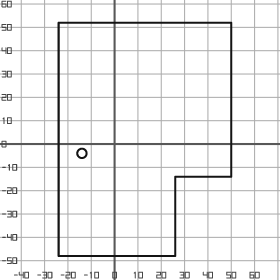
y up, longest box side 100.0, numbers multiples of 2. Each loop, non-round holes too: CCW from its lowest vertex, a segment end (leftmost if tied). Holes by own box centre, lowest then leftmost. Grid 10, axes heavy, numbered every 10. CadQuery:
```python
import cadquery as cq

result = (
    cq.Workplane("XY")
    .moveTo(-24.0, -48.0)
    .lineTo(26.0, -48.0)
    .lineTo(26.0, -14.0)
    .lineTo(50.0, -14.0)
    .lineTo(50.0, 52.0)
    .lineTo(-24.0, 52.0)
    .close()
    .moveTo(-14.0, -4.0)
    .circle(2.0)
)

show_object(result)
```